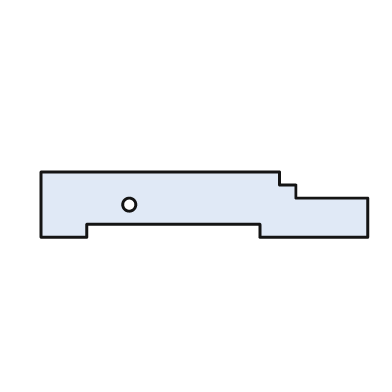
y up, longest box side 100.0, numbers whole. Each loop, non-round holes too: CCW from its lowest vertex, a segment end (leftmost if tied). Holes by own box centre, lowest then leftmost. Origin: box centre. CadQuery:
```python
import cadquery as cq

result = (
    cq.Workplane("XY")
    .moveTo(-50.0, -10.0)
    .lineTo(-36.0, -10.0)
    .lineTo(-36.0, -6.0)
    .lineTo(17.0, -6.0)
    .lineTo(17.0, -10.0)
    .lineTo(50.0, -10.0)
    .lineTo(50.0, 2.0)
    .lineTo(28.0, 2.0)
    .lineTo(28.0, 6.0)
    .lineTo(23.0, 6.0)
    .lineTo(23.0, 10.0)
    .lineTo(-50.0, 10.0)
    .close()
    .moveTo(-23.0, 0.0)
    .circle(2.0)
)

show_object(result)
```